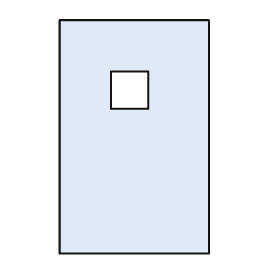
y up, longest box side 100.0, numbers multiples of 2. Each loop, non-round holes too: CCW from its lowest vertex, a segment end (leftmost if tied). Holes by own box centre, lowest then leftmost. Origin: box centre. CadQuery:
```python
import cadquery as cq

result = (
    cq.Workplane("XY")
    .moveTo(-32.0, -50.0)
    .lineTo(32.0, -50.0)
    .lineTo(32.0, 50.0)
    .lineTo(-32.0, 50.0)
    .close()
    .moveTo(-10.0, 12.0)
    .lineTo(6.0, 12.0)
    .lineTo(6.0, 28.0)
    .lineTo(-10.0, 28.0)
    .close()
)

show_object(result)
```